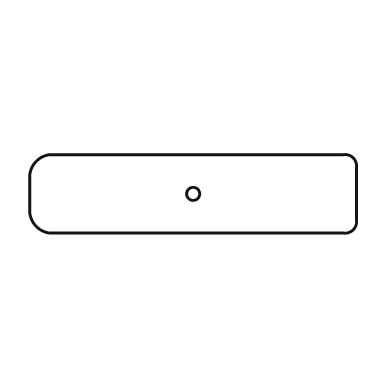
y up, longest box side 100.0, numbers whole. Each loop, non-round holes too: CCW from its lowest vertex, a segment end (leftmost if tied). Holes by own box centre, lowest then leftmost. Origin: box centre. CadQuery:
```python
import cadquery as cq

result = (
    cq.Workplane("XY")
    .moveTo(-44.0, -12.0)
    .lineTo(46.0, -12.0)
    .threePointArc((49.0, -11.0), (50.0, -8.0))
    .lineTo(50.0, 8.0)
    .threePointArc((49.0, 11.0), (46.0, 12.0))
    .lineTo(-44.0, 12.0)
    .threePointArc((-48.0, 10.0), (-50.0, 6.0))
    .lineTo(-50.0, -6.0)
    .threePointArc((-48.0, -10.0), (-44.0, -12.0))
    .close()
    .moveTo(0.0, 0.0)
    .circle(2.0)
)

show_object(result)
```